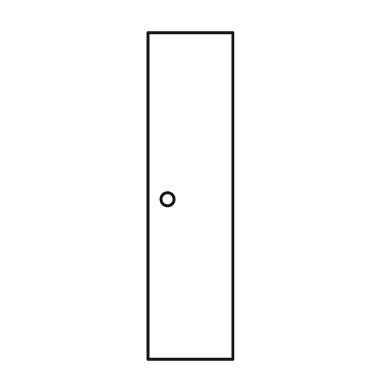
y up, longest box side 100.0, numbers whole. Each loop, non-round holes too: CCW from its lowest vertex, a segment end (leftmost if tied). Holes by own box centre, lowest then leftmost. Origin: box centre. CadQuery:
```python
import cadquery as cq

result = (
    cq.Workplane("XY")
    .moveTo(-13.0, -50.0)
    .lineTo(13.0, -50.0)
    .lineTo(13.0, 50.0)
    .lineTo(-13.0, 50.0)
    .close()
    .moveTo(-7.0, -1.0)
    .circle(2.0)
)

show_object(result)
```